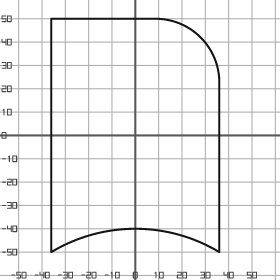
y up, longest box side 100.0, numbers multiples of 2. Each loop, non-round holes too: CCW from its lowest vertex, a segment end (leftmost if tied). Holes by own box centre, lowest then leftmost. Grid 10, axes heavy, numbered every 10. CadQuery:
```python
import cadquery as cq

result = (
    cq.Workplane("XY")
    .moveTo(-36.0, -50.0)
    .threePointArc((0.0, -40.0), (36.0, -50.0))
    .lineTo(36.0, 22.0)
    .threePointArc((28.0, 42.0), (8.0, 50.0))
    .lineTo(-36.0, 50.0)
    .close()
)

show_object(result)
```